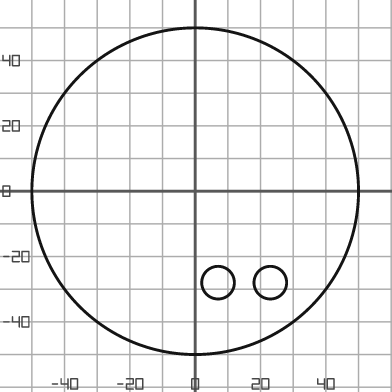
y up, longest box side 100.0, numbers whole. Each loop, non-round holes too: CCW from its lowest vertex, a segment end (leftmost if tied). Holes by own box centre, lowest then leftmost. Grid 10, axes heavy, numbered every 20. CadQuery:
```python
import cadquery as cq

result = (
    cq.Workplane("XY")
    .moveTo(0.0, 0.0)
    .circle(50.0)
    .moveTo(7.0, -28.0)
    .circle(5.0)
    .moveTo(23.0, -28.0)
    .circle(5.0)
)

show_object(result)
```